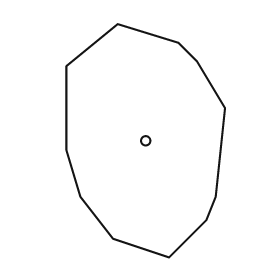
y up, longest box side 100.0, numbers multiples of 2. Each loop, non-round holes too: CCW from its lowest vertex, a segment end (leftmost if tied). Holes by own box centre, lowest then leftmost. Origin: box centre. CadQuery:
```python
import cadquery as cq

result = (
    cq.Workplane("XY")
    .moveTo(10.0, -50.0)
    .lineTo(26.0, -34.0)
    .lineTo(30.0, -24.0)
    .lineTo(34.0, 14.0)
    .lineTo(22.0, 34.0)
    .lineTo(14.0, 42.0)
    .lineTo(-12.0, 50.0)
    .lineTo(-34.0, 32.0)
    .lineTo(-34.0, -4.0)
    .lineTo(-28.0, -24.0)
    .lineTo(-14.0, -42.0)
    .close()
    .moveTo(0.0, 0.0)
    .circle(2.0)
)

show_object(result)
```